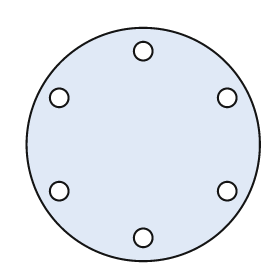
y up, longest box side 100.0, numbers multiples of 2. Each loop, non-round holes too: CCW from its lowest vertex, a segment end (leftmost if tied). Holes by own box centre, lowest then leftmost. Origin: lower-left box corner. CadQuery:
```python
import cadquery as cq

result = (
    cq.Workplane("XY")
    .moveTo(50.0, 50.0)
    .circle(50.0)
    .moveTo(50.0, 10.0)
    .circle(4.0)
    .moveTo(14.0, 30.0)
    .circle(4.0)
    .moveTo(86.0, 30.0)
    .circle(4.0)
    .moveTo(14.0, 70.0)
    .circle(4.0)
    .moveTo(86.0, 70.0)
    .circle(4.0)
    .moveTo(50.0, 90.0)
    .circle(4.0)
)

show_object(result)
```